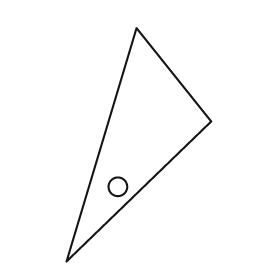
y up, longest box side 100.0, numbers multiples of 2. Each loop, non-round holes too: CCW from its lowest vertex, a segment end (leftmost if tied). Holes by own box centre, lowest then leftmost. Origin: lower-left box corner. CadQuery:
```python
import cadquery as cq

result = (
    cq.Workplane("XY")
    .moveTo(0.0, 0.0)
    .lineTo(62.0, 60.0)
    .lineTo(30.0, 100.0)
    .close()
    .moveTo(22.0, 32.0)
    .circle(4.0)
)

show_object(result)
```